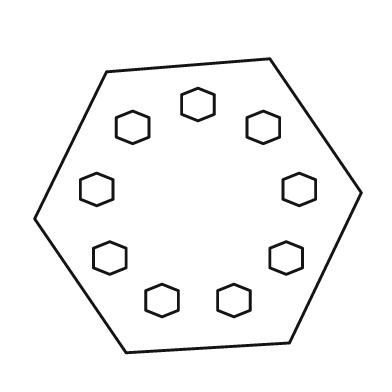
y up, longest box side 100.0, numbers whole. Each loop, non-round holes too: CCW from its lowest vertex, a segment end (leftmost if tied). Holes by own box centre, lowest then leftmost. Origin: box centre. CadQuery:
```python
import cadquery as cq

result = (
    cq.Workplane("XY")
    .moveTo(-22.0, -45.0)
    .lineTo(28.0, -42.0)
    .lineTo(50.0, 4.0)
    .lineTo(22.0, 45.0)
    .lineTo(-28.0, 41.0)
    .lineTo(-50.0, -4.0)
    .close()
    .moveTo(-11.0, -34.0)
    .lineTo(-6.0, -32.0)
    .lineTo(-6.0, -26.0)
    .lineTo(-11.0, -24.0)
    .lineTo(-16.0, -26.0)
    .lineTo(-16.0, -32.0)
    .close()
    .moveTo(11.0, -34.0)
    .lineTo(16.0, -32.0)
    .lineTo(16.0, -26.0)
    .lineTo(11.0, -24.0)
    .lineTo(6.0, -26.0)
    .lineTo(6.0, -32.0)
    .close()
    .moveTo(-27.0, -21.0)
    .lineTo(-22.0, -19.0)
    .lineTo(-22.0, -13.0)
    .lineTo(-27.0, -11.0)
    .lineTo(-32.0, -13.0)
    .lineTo(-32.0, -19.0)
    .close()
    .moveTo(27.0, -21.0)
    .lineTo(32.0, -19.0)
    .lineTo(32.0, -13.0)
    .lineTo(27.0, -11.0)
    .lineTo(22.0, -13.0)
    .lineTo(22.0, -19.0)
    .close()
    .moveTo(-31.0, 0.0)
    .lineTo(-26.0, 2.0)
    .lineTo(-26.0, 8.0)
    .lineTo(-31.0, 10.0)
    .lineTo(-36.0, 8.0)
    .lineTo(-36.0, 2.0)
    .close()
    .moveTo(31.0, 0.0)
    .lineTo(36.0, 2.0)
    .lineTo(36.0, 8.0)
    .lineTo(31.0, 10.0)
    .lineTo(26.0, 8.0)
    .lineTo(26.0, 2.0)
    .close()
    .moveTo(-20.0, 19.0)
    .lineTo(-15.0, 21.0)
    .lineTo(-15.0, 27.0)
    .lineTo(-20.0, 29.0)
    .lineTo(-25.0, 27.0)
    .lineTo(-25.0, 21.0)
    .close()
    .moveTo(20.0, 19.0)
    .lineTo(25.0, 21.0)
    .lineTo(25.0, 27.0)
    .lineTo(20.0, 29.0)
    .lineTo(15.0, 27.0)
    .lineTo(15.0, 21.0)
    .close()
    .moveTo(0.0, 26.0)
    .lineTo(5.0, 28.0)
    .lineTo(5.0, 34.0)
    .lineTo(0.0, 36.0)
    .lineTo(-5.0, 34.0)
    .lineTo(-5.0, 28.0)
    .close()
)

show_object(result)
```